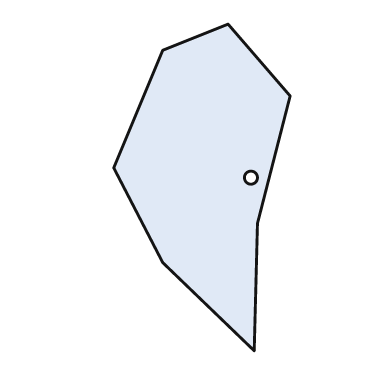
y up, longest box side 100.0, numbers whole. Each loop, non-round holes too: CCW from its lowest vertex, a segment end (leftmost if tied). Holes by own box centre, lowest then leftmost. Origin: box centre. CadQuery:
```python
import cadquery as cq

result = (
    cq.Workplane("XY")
    .moveTo(16.0, -50.0)
    .lineTo(17.0, -11.0)
    .lineTo(27.0, 28.0)
    .lineTo(8.0, 50.0)
    .lineTo(-12.0, 42.0)
    .lineTo(-27.0, 6.0)
    .lineTo(-12.0, -23.0)
    .close()
    .moveTo(15.0, 3.0)
    .circle(2.0)
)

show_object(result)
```